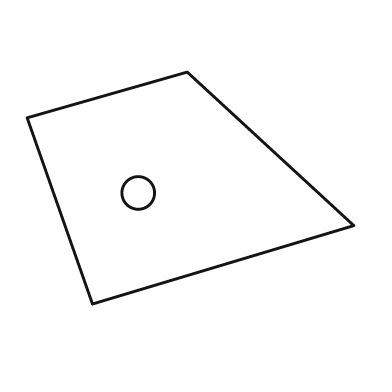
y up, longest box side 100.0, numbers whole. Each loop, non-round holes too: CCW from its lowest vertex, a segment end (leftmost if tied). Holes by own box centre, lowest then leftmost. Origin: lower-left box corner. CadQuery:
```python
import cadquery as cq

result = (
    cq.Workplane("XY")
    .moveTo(20.0, 0.0)
    .lineTo(100.0, 24.0)
    .lineTo(49.0, 71.0)
    .lineTo(0.0, 57.0)
    .close()
    .moveTo(34.0, 34.0)
    .circle(5.0)
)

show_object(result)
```